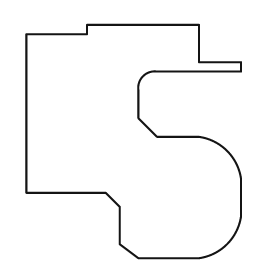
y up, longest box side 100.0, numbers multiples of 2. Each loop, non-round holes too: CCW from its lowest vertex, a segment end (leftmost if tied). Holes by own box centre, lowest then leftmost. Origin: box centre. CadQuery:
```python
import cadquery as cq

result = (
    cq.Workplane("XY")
    .moveTo(2.0, -50.0)
    .lineTo(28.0, -50.0)
    .threePointArc((40.0, -44.0), (46.0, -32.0))
    .lineTo(46.0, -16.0)
    .threePointArc((40.0, -4.0), (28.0, 2.0))
    .lineTo(10.0, 2.0)
    .lineTo(2.0, 10.0)
    .lineTo(2.0, 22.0)
    .threePointArc((4.0, 28.0), (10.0, 30.0))
    .lineTo(46.0, 30.0)
    .lineTo(46.0, 34.0)
    .lineTo(28.0, 34.0)
    .lineTo(28.0, 50.0)
    .lineTo(-20.0, 50.0)
    .lineTo(-20.0, 46.0)
    .lineTo(-46.0, 46.0)
    .lineTo(-46.0, -22.0)
    .lineTo(-12.0, -22.0)
    .lineTo(-6.0, -28.0)
    .lineTo(-6.0, -44.0)
    .close()
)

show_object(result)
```